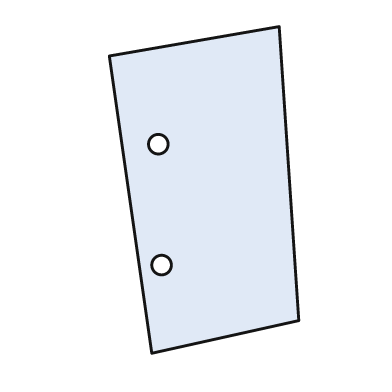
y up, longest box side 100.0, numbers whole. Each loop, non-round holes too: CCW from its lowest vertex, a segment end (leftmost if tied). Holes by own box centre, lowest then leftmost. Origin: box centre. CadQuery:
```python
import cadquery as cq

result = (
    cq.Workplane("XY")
    .moveTo(-16.0, -50.0)
    .lineTo(29.0, -40.0)
    .lineTo(23.0, 50.0)
    .lineTo(-29.0, 41.0)
    .close()
    .moveTo(-13.0, -23.0)
    .circle(3.0)
    .moveTo(-14.0, 14.0)
    .circle(3.0)
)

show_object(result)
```